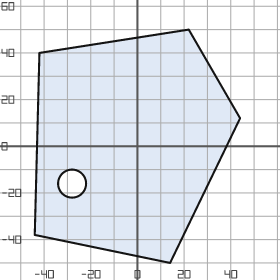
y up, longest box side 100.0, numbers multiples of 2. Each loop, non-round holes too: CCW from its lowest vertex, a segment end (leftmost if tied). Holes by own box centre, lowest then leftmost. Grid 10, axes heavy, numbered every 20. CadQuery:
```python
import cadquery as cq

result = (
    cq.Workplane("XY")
    .moveTo(14.0, -50.0)
    .lineTo(44.0, 12.0)
    .lineTo(22.0, 50.0)
    .lineTo(-42.0, 40.0)
    .lineTo(-44.0, -38.0)
    .close()
    .moveTo(-28.0, -16.0)
    .circle(6.0)
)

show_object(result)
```